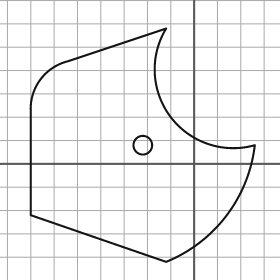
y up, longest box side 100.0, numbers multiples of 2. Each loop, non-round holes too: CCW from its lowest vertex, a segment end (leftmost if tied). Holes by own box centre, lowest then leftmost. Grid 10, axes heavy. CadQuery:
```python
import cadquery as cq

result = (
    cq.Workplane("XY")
    .moveTo(-12.0, -42.0)
    .threePointArc((14.0, -22.0), (26.0, 8.0))
    .threePointArc((-10.0, 20.0), (-12.0, 58.0))
    .lineTo(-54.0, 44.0)
    .threePointArc((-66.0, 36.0), (-70.0, 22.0))
    .lineTo(-70.0, -22.0)
    .close()
    .moveTo(-22.0, 8.0)
    .circle(4.0)
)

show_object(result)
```